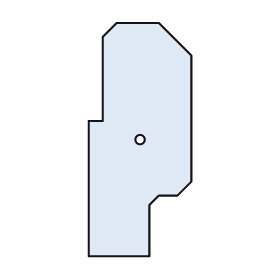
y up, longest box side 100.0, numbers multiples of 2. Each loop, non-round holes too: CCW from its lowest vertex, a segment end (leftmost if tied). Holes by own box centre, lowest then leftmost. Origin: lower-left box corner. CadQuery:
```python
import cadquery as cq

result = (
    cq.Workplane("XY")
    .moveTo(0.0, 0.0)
    .lineTo(26.0, 0.0)
    .lineTo(26.0, 22.0)
    .lineTo(30.0, 26.0)
    .lineTo(38.0, 26.0)
    .lineTo(44.0, 32.0)
    .lineTo(44.0, 86.0)
    .lineTo(30.0, 100.0)
    .lineTo(12.0, 100.0)
    .lineTo(6.0, 94.0)
    .lineTo(6.0, 58.0)
    .lineTo(0.0, 58.0)
    .close()
    .moveTo(22.0, 50.0)
    .circle(2.0)
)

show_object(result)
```